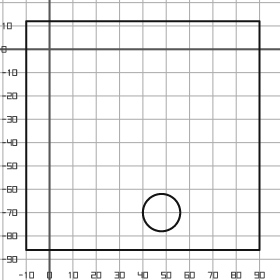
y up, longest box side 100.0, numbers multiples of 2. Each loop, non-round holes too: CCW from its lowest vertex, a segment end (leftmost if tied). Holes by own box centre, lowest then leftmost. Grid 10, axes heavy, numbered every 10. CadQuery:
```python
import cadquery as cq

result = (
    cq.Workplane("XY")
    .moveTo(-10.0, -86.0)
    .lineTo(90.0, -86.0)
    .lineTo(90.0, 12.0)
    .lineTo(-10.0, 12.0)
    .close()
    .moveTo(48.0, -70.0)
    .circle(8.0)
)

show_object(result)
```